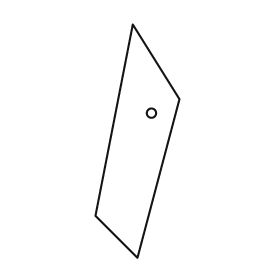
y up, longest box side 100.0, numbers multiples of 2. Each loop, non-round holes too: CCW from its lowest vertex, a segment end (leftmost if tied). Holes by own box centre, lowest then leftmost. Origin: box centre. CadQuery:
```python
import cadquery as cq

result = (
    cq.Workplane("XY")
    .moveTo(0.0, -50.0)
    .lineTo(18.0, 18.0)
    .lineTo(-2.0, 50.0)
    .lineTo(-18.0, -32.0)
    .close()
    .moveTo(6.0, 12.0)
    .circle(2.0)
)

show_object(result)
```